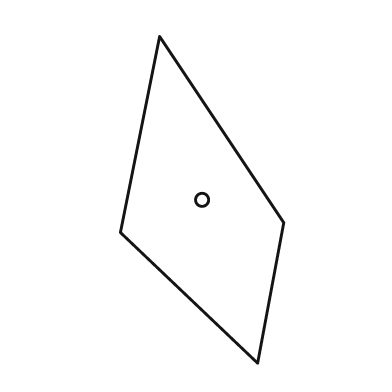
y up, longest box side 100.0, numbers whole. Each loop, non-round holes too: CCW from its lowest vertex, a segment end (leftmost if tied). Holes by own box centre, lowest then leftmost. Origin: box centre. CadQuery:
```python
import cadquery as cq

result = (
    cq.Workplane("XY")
    .moveTo(17.0, -50.0)
    .lineTo(25.0, -7.0)
    .lineTo(-13.0, 50.0)
    .lineTo(-25.0, -10.0)
    .close()
    .moveTo(0.0, 0.0)
    .circle(2.0)
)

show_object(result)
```